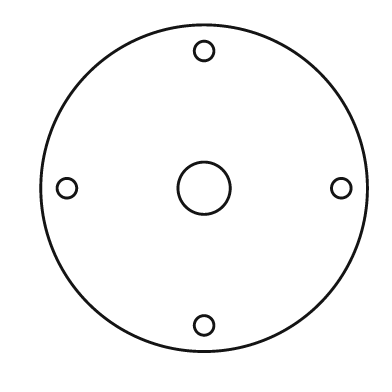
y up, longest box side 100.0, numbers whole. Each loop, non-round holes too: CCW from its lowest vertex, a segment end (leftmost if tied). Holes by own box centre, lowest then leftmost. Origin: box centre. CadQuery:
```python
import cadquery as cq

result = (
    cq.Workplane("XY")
    .moveTo(0.0, 0.0)
    .circle(50.0)
    .moveTo(0.0, -42.0)
    .circle(3.0)
    .moveTo(-42.0, 0.0)
    .circle(3.0)
    .moveTo(0.0, 0.0)
    .circle(8.0)
    .moveTo(42.0, 0.0)
    .circle(3.0)
    .moveTo(0.0, 42.0)
    .circle(3.0)
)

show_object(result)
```